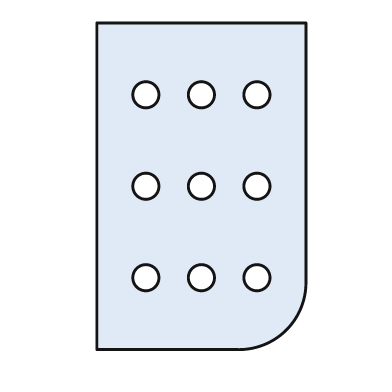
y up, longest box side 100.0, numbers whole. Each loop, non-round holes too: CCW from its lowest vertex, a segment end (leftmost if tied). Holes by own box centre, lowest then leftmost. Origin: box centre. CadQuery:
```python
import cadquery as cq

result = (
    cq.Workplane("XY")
    .moveTo(-32.0, -50.0)
    .lineTo(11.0, -50.0)
    .threePointArc((26.0, -44.0), (32.0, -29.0))
    .lineTo(32.0, 50.0)
    .lineTo(-32.0, 50.0)
    .close()
    .moveTo(-17.0, -28.0)
    .circle(4.0)
    .moveTo(0.0, -28.0)
    .circle(4.0)
    .moveTo(17.0, -28.0)
    .circle(4.0)
    .moveTo(-17.0, 0.0)
    .circle(4.0)
    .moveTo(0.0, 0.0)
    .circle(4.0)
    .moveTo(17.0, 0.0)
    .circle(4.0)
    .moveTo(-17.0, 28.0)
    .circle(4.0)
    .moveTo(0.0, 28.0)
    .circle(4.0)
    .moveTo(17.0, 28.0)
    .circle(4.0)
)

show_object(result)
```